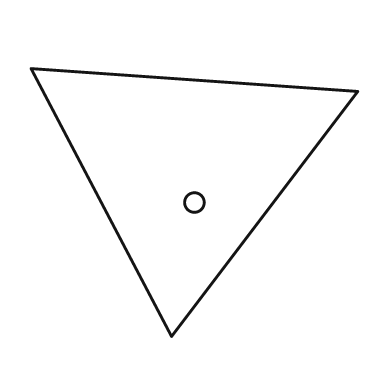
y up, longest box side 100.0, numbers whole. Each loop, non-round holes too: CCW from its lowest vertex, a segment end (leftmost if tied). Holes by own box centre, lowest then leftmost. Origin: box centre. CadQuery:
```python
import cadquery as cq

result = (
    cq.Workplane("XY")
    .moveTo(-7.0, -41.0)
    .lineTo(50.0, 34.0)
    .lineTo(-50.0, 41.0)
    .close()
    .moveTo(0.0, 0.0)
    .circle(3.0)
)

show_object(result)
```